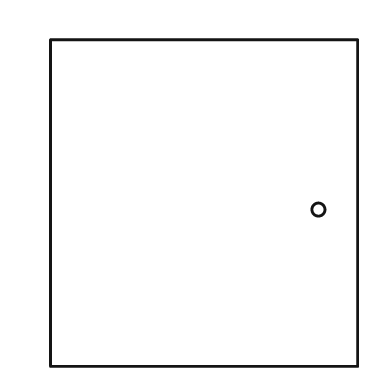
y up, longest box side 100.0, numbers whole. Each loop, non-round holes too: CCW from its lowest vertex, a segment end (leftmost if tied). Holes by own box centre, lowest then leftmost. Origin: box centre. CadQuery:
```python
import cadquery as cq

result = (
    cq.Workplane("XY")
    .moveTo(-47.0, -50.0)
    .lineTo(47.0, -50.0)
    .lineTo(47.0, 50.0)
    .lineTo(-47.0, 50.0)
    .close()
    .moveTo(35.0, -2.0)
    .circle(2.0)
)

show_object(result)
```